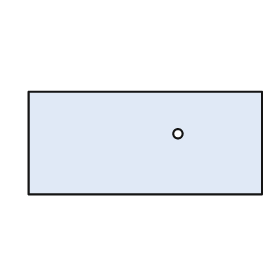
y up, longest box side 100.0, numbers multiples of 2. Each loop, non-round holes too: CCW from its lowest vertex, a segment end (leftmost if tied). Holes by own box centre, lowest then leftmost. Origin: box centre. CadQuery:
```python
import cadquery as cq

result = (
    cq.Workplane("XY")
    .moveTo(-50.0, -22.0)
    .lineTo(50.0, -22.0)
    .lineTo(50.0, 22.0)
    .lineTo(-50.0, 22.0)
    .close()
    .moveTo(14.0, 4.0)
    .circle(2.0)
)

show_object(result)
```